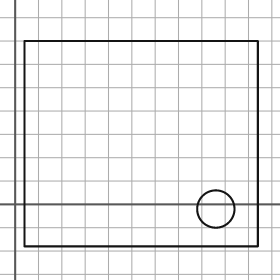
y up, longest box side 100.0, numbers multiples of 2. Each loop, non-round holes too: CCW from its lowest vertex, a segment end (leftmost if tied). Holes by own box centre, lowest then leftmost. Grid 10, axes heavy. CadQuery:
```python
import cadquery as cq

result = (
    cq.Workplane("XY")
    .moveTo(4.0, -18.0)
    .lineTo(104.0, -18.0)
    .lineTo(104.0, 70.0)
    .lineTo(4.0, 70.0)
    .close()
    .moveTo(86.0, -2.0)
    .circle(8.0)
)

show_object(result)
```